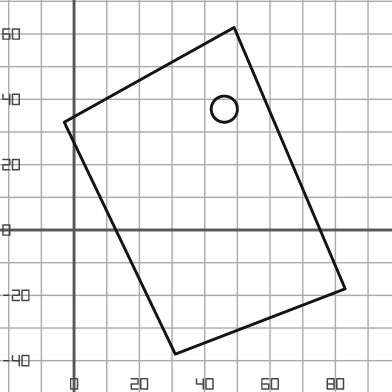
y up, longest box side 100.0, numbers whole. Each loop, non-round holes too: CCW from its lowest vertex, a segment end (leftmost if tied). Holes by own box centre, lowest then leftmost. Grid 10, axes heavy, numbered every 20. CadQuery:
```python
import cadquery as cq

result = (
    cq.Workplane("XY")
    .moveTo(31.0, -38.0)
    .lineTo(83.0, -18.0)
    .lineTo(49.0, 62.0)
    .lineTo(-3.0, 33.0)
    .close()
    .moveTo(46.0, 37.0)
    .circle(4.0)
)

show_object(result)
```